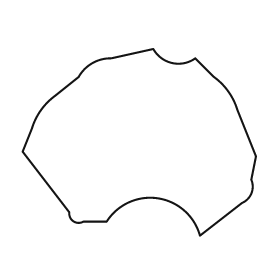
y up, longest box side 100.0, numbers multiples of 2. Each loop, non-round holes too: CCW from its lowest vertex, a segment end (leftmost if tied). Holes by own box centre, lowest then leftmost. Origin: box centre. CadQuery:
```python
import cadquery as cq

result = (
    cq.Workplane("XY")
    .moveTo(26.0, -40.0)
    .lineTo(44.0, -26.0)
    .threePointArc((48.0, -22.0), (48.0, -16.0))
    .lineTo(50.0, -6.0)
    .lineTo(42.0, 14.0)
    .threePointArc((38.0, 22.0), (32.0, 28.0))
    .lineTo(24.0, 36.0)
    .threePointArc((14.0, 34.0), (6.0, 40.0))
    .lineTo(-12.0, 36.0)
    .threePointArc((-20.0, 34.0), (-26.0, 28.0))
    .lineTo(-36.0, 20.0)
    .threePointArc((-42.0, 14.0), (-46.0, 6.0))
    .lineTo(-50.0, -4.0)
    .lineTo(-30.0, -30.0)
    .threePointArc((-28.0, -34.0), (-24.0, -34.0))
    .lineTo(-14.0, -34.0)
    .threePointArc((8.0, -24.0), (26.0, -40.0))
    .close()
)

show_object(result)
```